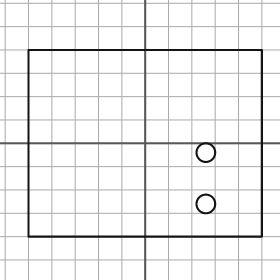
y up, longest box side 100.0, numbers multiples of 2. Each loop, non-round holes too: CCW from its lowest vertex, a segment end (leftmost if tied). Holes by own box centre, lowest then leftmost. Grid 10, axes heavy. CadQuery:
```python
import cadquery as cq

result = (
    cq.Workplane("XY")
    .moveTo(-50.0, -40.0)
    .lineTo(50.0, -40.0)
    .lineTo(50.0, 40.0)
    .lineTo(-50.0, 40.0)
    .close()
    .moveTo(26.0, -26.0)
    .circle(4.0)
    .moveTo(26.0, -4.0)
    .circle(4.0)
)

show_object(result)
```